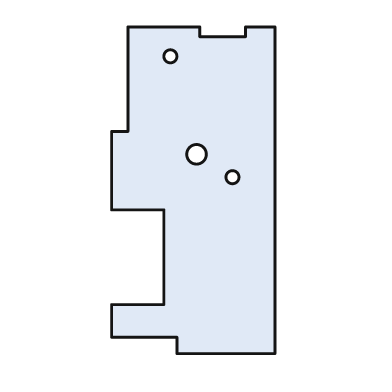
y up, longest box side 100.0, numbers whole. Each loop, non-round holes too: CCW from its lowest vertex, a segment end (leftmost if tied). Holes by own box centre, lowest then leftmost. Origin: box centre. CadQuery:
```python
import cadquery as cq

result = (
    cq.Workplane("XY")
    .moveTo(-5.0, -50.0)
    .lineTo(25.0, -50.0)
    .lineTo(25.0, 50.0)
    .lineTo(16.0, 50.0)
    .lineTo(16.0, 47.0)
    .lineTo(2.0, 47.0)
    .lineTo(2.0, 50.0)
    .lineTo(-20.0, 50.0)
    .lineTo(-20.0, 18.0)
    .lineTo(-25.0, 18.0)
    .lineTo(-25.0, -6.0)
    .lineTo(-9.0, -6.0)
    .lineTo(-9.0, -35.0)
    .lineTo(-25.0, -35.0)
    .lineTo(-25.0, -45.0)
    .lineTo(-5.0, -45.0)
    .close()
    .moveTo(12.0, 4.0)
    .circle(2.0)
    .moveTo(1.0, 11.0)
    .circle(3.0)
    .moveTo(-7.0, 41.0)
    .circle(2.0)
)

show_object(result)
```